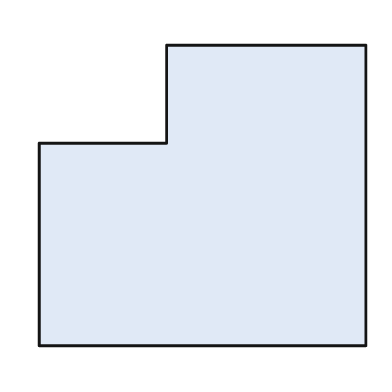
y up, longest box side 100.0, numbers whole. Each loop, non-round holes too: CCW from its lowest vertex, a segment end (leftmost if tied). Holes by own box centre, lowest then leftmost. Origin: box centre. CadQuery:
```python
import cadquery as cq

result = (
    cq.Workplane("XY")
    .moveTo(-50.0, -46.0)
    .lineTo(50.0, -46.0)
    .lineTo(50.0, 46.0)
    .lineTo(-11.0, 46.0)
    .lineTo(-11.0, 16.0)
    .lineTo(-50.0, 16.0)
    .close()
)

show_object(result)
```